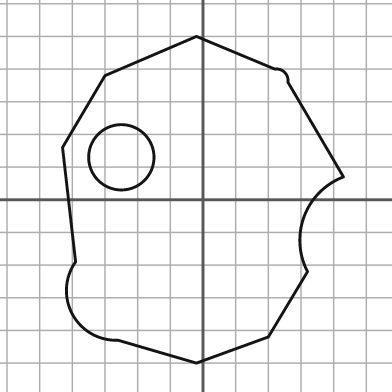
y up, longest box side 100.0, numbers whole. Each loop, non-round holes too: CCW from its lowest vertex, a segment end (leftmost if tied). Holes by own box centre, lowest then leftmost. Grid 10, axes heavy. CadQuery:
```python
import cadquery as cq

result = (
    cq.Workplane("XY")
    .moveTo(-2.0, -50.0)
    .lineTo(20.0, -42.0)
    .lineTo(32.0, -22.0)
    .threePointArc((31.0, -5.0), (43.0, 7.0))
    .lineTo(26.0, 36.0)
    .threePointArc((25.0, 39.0), (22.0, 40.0))
    .lineTo(-2.0, 50.0)
    .lineTo(-30.0, 38.0)
    .lineTo(-43.0, 16.0)
    .lineTo(-39.0, -19.0)
    .threePointArc((-40.0, -35.0), (-26.0, -43.0))
    .close()
    .moveTo(-25.0, 13.0)
    .circle(10.0)
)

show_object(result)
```